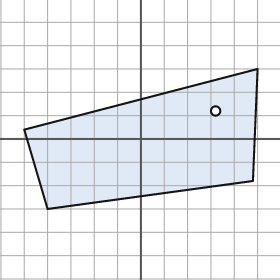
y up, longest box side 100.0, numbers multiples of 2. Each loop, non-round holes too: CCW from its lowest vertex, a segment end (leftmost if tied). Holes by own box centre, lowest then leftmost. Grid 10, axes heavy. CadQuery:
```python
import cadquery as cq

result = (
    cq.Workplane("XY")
    .moveTo(-40.0, -30.0)
    .lineTo(48.0, -18.0)
    .lineTo(50.0, 30.0)
    .lineTo(-50.0, 4.0)
    .close()
    .moveTo(32.0, 12.0)
    .circle(2.0)
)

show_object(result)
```